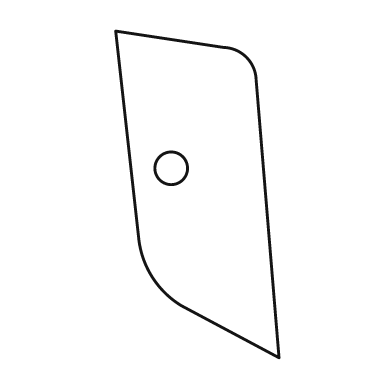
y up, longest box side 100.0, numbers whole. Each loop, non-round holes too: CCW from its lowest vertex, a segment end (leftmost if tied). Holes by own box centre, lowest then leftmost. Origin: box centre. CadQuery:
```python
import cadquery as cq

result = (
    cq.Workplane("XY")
    .moveTo(25.0, -50.0)
    .lineTo(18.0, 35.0)
    .threePointArc((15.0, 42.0), (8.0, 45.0))
    .lineTo(-25.0, 50.0)
    .lineTo(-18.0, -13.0)
    .threePointArc((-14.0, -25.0), (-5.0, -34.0))
    .close()
    .moveTo(-8.0, 8.0)
    .circle(5.0)
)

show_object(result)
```